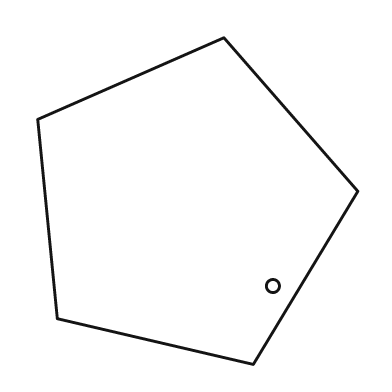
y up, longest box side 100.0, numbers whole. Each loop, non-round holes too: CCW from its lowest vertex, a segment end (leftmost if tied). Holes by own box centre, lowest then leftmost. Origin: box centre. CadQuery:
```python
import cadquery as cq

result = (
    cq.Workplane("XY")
    .moveTo(17.0, -50.0)
    .lineTo(49.0, 3.0)
    .lineTo(8.0, 50.0)
    .lineTo(-49.0, 25.0)
    .lineTo(-43.0, -36.0)
    .close()
    .moveTo(23.0, -26.0)
    .circle(2.0)
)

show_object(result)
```